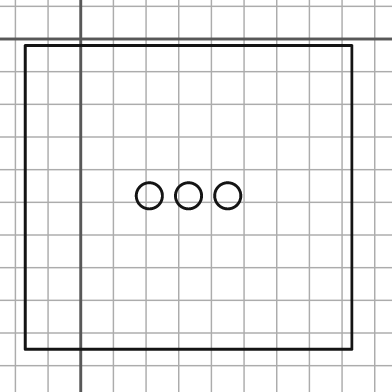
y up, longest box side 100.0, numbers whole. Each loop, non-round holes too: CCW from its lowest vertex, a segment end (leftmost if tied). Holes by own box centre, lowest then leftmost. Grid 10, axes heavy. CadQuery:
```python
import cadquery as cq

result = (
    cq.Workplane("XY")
    .moveTo(-17.0, -95.0)
    .lineTo(83.0, -95.0)
    .lineTo(83.0, -2.0)
    .lineTo(-17.0, -2.0)
    .close()
    .moveTo(21.0, -48.0)
    .circle(4.0)
    .moveTo(33.0, -48.0)
    .circle(4.0)
    .moveTo(45.0, -48.0)
    .circle(4.0)
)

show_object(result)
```